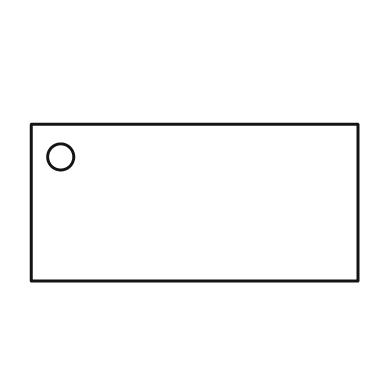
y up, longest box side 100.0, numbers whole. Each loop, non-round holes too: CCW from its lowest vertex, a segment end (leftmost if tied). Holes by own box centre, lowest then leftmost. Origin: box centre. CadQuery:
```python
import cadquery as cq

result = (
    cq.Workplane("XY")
    .moveTo(-50.0, -24.0)
    .lineTo(50.0, -24.0)
    .lineTo(50.0, 24.0)
    .lineTo(-50.0, 24.0)
    .close()
    .moveTo(-41.0, 14.0)
    .circle(4.0)
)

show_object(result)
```